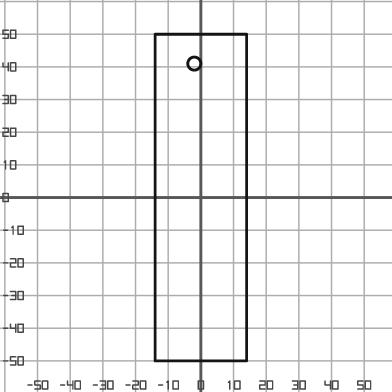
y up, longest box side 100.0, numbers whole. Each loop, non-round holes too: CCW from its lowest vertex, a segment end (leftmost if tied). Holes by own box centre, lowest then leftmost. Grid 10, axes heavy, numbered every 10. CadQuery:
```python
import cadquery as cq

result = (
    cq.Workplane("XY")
    .moveTo(-14.0, -50.0)
    .lineTo(14.0, -50.0)
    .lineTo(14.0, 50.0)
    .lineTo(-14.0, 50.0)
    .close()
    .moveTo(-2.0, 41.0)
    .circle(2.0)
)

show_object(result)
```